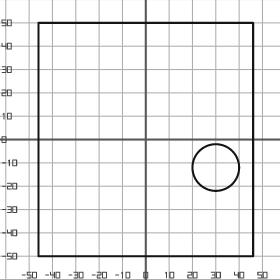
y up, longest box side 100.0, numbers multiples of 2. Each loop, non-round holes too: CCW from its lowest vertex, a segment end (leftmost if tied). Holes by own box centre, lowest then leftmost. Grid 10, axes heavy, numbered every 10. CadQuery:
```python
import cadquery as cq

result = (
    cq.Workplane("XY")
    .moveTo(-46.0, -50.0)
    .lineTo(46.0, -50.0)
    .lineTo(46.0, 50.0)
    .lineTo(-46.0, 50.0)
    .close()
    .moveTo(30.0, -12.0)
    .circle(10.0)
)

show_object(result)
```